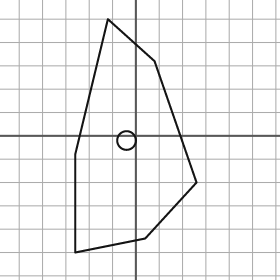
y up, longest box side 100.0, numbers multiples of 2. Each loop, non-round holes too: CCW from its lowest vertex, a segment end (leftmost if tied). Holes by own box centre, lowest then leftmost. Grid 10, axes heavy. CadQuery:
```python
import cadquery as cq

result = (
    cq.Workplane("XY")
    .moveTo(-26.0, -50.0)
    .lineTo(4.0, -44.0)
    .lineTo(26.0, -20.0)
    .lineTo(8.0, 32.0)
    .lineTo(-12.0, 50.0)
    .lineTo(-26.0, -8.0)
    .close()
    .moveTo(-4.0, -2.0)
    .circle(4.0)
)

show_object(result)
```